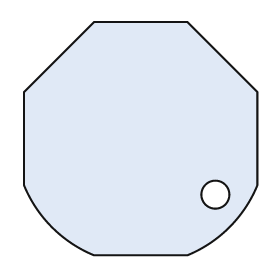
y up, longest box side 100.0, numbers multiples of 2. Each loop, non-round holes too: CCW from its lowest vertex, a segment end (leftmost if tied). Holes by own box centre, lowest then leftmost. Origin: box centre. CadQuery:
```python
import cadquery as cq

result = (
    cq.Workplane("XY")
    .moveTo(-20.0, -50.0)
    .lineTo(20.0, -50.0)
    .threePointArc((38.0, -38.0), (50.0, -20.0))
    .lineTo(50.0, 20.0)
    .lineTo(20.0, 50.0)
    .lineTo(-20.0, 50.0)
    .lineTo(-50.0, 20.0)
    .lineTo(-50.0, -20.0)
    .threePointArc((-38.0, -38.0), (-20.0, -50.0))
    .close()
    .moveTo(32.0, -24.0)
    .circle(6.0)
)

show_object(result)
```